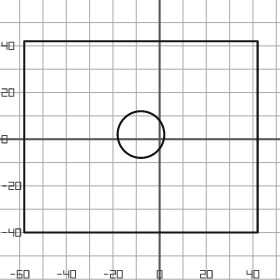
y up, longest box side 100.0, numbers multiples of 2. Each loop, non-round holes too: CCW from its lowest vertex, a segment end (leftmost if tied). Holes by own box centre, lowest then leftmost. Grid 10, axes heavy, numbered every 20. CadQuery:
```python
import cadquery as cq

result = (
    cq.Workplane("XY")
    .moveTo(-58.0, -40.0)
    .lineTo(42.0, -40.0)
    .lineTo(42.0, 42.0)
    .lineTo(-58.0, 42.0)
    .close()
    .moveTo(-8.0, 2.0)
    .circle(10.0)
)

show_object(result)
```